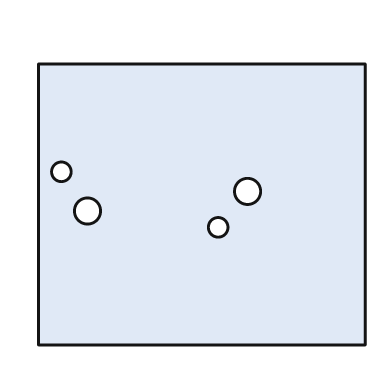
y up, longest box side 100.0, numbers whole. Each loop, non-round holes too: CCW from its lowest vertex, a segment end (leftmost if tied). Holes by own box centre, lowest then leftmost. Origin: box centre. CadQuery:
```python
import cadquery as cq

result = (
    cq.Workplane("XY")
    .moveTo(-50.0, -43.0)
    .lineTo(50.0, -43.0)
    .lineTo(50.0, 43.0)
    .lineTo(-50.0, 43.0)
    .close()
    .moveTo(5.0, -7.0)
    .circle(3.0)
    .moveTo(-35.0, -2.0)
    .circle(4.0)
    .moveTo(14.0, 4.0)
    .circle(4.0)
    .moveTo(-43.0, 10.0)
    .circle(3.0)
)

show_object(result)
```